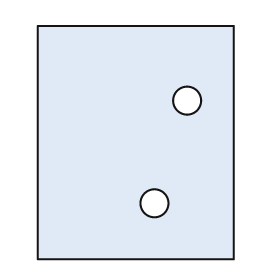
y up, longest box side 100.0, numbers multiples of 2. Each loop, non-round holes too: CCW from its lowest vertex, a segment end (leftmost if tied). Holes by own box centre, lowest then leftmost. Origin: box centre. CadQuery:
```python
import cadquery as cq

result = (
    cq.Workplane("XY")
    .moveTo(-42.0, -50.0)
    .lineTo(42.0, -50.0)
    .lineTo(42.0, 50.0)
    .lineTo(-42.0, 50.0)
    .close()
    .moveTo(8.0, -26.0)
    .circle(6.0)
    .moveTo(22.0, 18.0)
    .circle(6.0)
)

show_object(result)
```